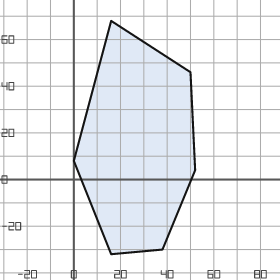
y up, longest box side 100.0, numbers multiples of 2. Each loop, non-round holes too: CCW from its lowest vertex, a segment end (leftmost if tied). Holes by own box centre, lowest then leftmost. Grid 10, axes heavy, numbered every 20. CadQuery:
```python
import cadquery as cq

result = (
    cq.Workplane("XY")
    .moveTo(16.0, -32.0)
    .lineTo(38.0, -30.0)
    .lineTo(52.0, 4.0)
    .lineTo(50.0, 46.0)
    .lineTo(16.0, 68.0)
    .lineTo(0.0, 8.0)
    .close()
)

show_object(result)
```